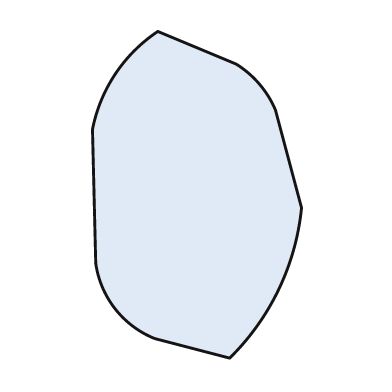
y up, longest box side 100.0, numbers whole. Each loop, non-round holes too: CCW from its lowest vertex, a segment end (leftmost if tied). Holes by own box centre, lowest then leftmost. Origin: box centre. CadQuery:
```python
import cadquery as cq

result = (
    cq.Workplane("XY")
    .moveTo(10.0, -50.0)
    .threePointArc((25.0, -29.0), (32.0, -4.0))
    .lineTo(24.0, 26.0)
    .threePointArc((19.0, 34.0), (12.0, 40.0))
    .lineTo(-12.0, 50.0)
    .threePointArc((-25.0, 37.0), (-32.0, 20.0))
    .lineTo(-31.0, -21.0)
    .threePointArc((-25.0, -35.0), (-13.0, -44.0))
    .close()
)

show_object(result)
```